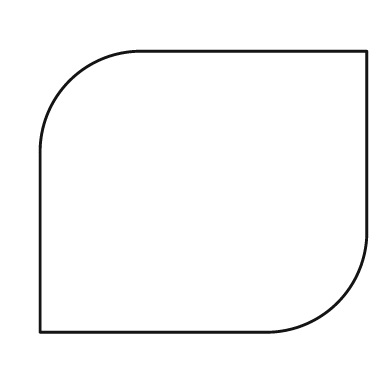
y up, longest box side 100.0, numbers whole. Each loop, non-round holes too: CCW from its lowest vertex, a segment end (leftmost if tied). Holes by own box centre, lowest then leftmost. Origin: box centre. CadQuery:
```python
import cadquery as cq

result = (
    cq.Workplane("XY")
    .moveTo(-50.0, -43.0)
    .lineTo(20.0, -43.0)
    .threePointArc((41.0, -34.0), (50.0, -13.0))
    .lineTo(50.0, 43.0)
    .lineTo(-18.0, 43.0)
    .threePointArc((-41.0, 34.0), (-50.0, 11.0))
    .close()
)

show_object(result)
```